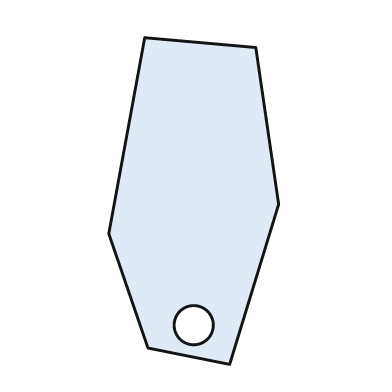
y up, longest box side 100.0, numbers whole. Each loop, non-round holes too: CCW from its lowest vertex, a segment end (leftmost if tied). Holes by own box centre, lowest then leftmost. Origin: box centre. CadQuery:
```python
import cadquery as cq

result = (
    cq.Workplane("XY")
    .moveTo(11.0, -50.0)
    .lineTo(26.0, -1.0)
    .lineTo(19.0, 47.0)
    .lineTo(-15.0, 50.0)
    .lineTo(-26.0, -10.0)
    .lineTo(-14.0, -45.0)
    .close()
    .moveTo(0.0, -38.0)
    .circle(6.0)
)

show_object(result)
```